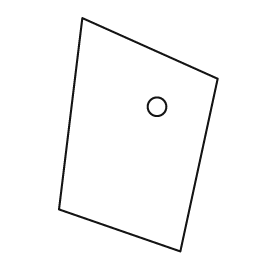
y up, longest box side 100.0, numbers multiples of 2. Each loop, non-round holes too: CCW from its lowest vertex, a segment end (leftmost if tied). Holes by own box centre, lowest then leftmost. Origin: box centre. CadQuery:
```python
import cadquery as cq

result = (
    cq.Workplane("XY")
    .moveTo(18.0, -50.0)
    .lineTo(34.0, 24.0)
    .lineTo(-24.0, 50.0)
    .lineTo(-34.0, -32.0)
    .close()
    .moveTo(8.0, 12.0)
    .circle(4.0)
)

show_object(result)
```